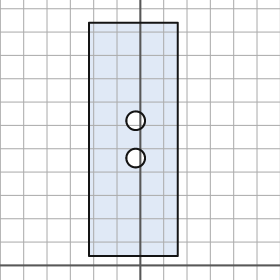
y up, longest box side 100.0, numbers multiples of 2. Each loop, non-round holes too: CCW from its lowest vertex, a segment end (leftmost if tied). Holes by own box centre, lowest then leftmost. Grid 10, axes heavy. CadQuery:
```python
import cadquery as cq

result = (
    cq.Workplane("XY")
    .moveTo(-22.0, 4.0)
    .lineTo(16.0, 4.0)
    .lineTo(16.0, 104.0)
    .lineTo(-22.0, 104.0)
    .close()
    .moveTo(-2.0, 46.0)
    .circle(4.0)
    .moveTo(-2.0, 62.0)
    .circle(4.0)
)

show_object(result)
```